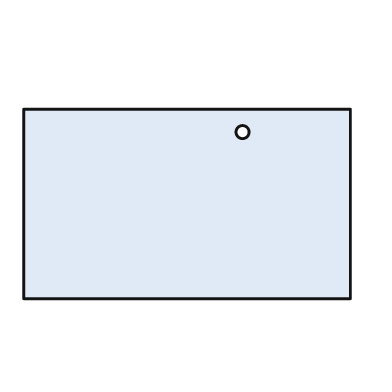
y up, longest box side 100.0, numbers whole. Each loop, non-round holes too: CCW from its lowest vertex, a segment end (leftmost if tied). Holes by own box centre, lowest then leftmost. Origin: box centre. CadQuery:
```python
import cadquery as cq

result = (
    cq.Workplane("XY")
    .moveTo(-50.0, -29.0)
    .lineTo(50.0, -29.0)
    .lineTo(50.0, 29.0)
    .lineTo(-50.0, 29.0)
    .close()
    .moveTo(17.0, 22.0)
    .circle(2.0)
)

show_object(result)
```